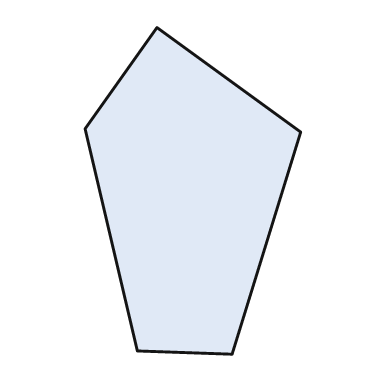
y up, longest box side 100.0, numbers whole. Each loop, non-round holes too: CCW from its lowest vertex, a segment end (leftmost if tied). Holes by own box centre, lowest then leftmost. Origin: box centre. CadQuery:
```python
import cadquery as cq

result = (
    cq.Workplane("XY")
    .moveTo(12.0, -50.0)
    .lineTo(33.0, 18.0)
    .lineTo(-11.0, 50.0)
    .lineTo(-33.0, 19.0)
    .lineTo(-17.0, -49.0)
    .close()
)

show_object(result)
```